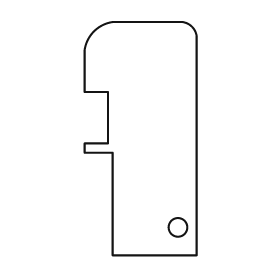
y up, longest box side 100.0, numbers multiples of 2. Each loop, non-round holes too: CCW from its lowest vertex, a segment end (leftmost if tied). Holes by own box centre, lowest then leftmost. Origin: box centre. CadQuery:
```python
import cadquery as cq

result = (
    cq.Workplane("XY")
    .moveTo(-12.0, -50.0)
    .lineTo(24.0, -50.0)
    .lineTo(24.0, 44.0)
    .threePointArc((22.0, 48.0), (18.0, 50.0))
    .lineTo(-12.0, 50.0)
    .threePointArc((-20.0, 46.0), (-24.0, 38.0))
    .lineTo(-24.0, 20.0)
    .lineTo(-14.0, 20.0)
    .lineTo(-14.0, -2.0)
    .lineTo(-24.0, -2.0)
    .lineTo(-24.0, -6.0)
    .lineTo(-12.0, -6.0)
    .close()
    .moveTo(16.0, -38.0)
    .circle(4.0)
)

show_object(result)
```